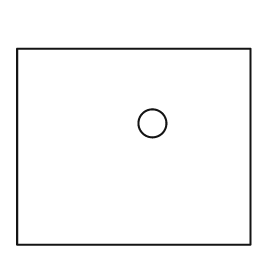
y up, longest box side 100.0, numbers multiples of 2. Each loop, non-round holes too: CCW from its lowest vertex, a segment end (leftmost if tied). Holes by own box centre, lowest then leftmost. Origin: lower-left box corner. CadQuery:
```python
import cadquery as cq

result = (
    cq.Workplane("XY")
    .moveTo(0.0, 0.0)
    .lineTo(100.0, 0.0)
    .lineTo(100.0, 84.0)
    .lineTo(0.0, 84.0)
    .close()
    .moveTo(58.0, 52.0)
    .circle(6.0)
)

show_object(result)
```